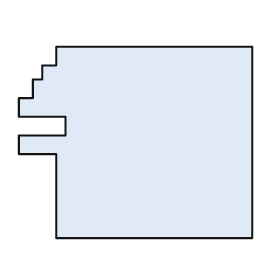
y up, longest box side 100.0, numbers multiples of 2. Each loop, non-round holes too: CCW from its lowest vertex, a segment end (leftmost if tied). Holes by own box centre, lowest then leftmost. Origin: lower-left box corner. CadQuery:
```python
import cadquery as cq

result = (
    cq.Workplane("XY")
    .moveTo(16.0, 0.0)
    .lineTo(100.0, 0.0)
    .lineTo(100.0, 82.0)
    .lineTo(16.0, 82.0)
    .lineTo(16.0, 74.0)
    .lineTo(10.0, 74.0)
    .lineTo(10.0, 68.0)
    .lineTo(6.0, 68.0)
    .lineTo(6.0, 60.0)
    .lineTo(0.0, 60.0)
    .lineTo(0.0, 52.0)
    .lineTo(20.0, 52.0)
    .lineTo(20.0, 44.0)
    .lineTo(0.0, 44.0)
    .lineTo(0.0, 36.0)
    .lineTo(16.0, 36.0)
    .close()
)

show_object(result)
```